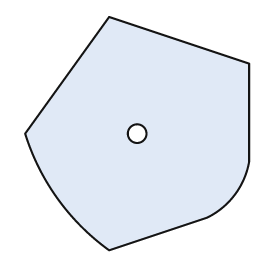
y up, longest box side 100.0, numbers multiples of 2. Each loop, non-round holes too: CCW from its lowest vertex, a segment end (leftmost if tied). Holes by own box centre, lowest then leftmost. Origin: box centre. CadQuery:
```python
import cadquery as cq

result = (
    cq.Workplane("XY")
    .moveTo(-12.0, -50.0)
    .lineTo(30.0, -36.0)
    .threePointArc((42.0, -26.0), (48.0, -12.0))
    .lineTo(48.0, 30.0)
    .lineTo(-12.0, 50.0)
    .lineTo(-48.0, 0.0)
    .threePointArc((-34.0, -28.0), (-12.0, -50.0))
    .close()
    .moveTo(0.0, 0.0)
    .circle(4.0)
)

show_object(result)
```